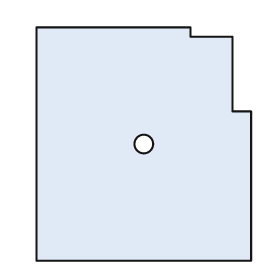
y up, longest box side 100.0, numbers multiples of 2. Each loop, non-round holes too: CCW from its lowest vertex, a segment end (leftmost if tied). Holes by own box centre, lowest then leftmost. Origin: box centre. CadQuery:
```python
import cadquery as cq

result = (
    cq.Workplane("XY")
    .moveTo(-46.0, -50.0)
    .lineTo(46.0, -50.0)
    .lineTo(46.0, 14.0)
    .lineTo(38.0, 14.0)
    .lineTo(38.0, 46.0)
    .lineTo(20.0, 46.0)
    .lineTo(20.0, 50.0)
    .lineTo(-46.0, 50.0)
    .close()
    .moveTo(0.0, 0.0)
    .circle(4.0)
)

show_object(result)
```